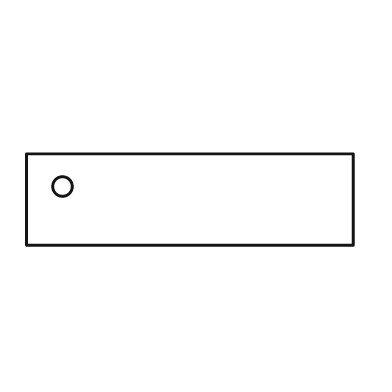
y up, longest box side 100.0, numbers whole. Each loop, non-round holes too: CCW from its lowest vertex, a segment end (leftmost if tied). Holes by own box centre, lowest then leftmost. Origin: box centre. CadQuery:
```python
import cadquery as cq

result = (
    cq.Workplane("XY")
    .moveTo(-50.0, -14.0)
    .lineTo(50.0, -14.0)
    .lineTo(50.0, 14.0)
    .lineTo(-50.0, 14.0)
    .close()
    .moveTo(-39.0, 4.0)
    .circle(3.0)
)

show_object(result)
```